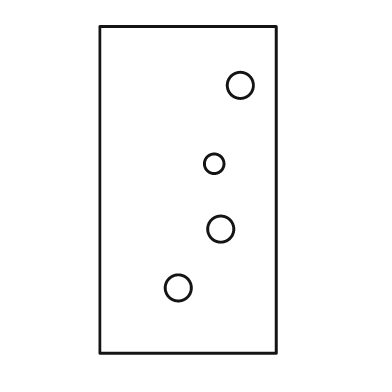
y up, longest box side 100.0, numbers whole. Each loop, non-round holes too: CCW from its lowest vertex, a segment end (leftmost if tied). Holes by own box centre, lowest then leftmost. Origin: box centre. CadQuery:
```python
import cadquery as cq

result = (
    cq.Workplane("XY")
    .moveTo(-27.0, -50.0)
    .lineTo(27.0, -50.0)
    .lineTo(27.0, 50.0)
    .lineTo(-27.0, 50.0)
    .close()
    .moveTo(-3.0, -30.0)
    .circle(4.0)
    .moveTo(10.0, -12.0)
    .circle(4.0)
    .moveTo(8.0, 8.0)
    .circle(3.0)
    .moveTo(16.0, 32.0)
    .circle(4.0)
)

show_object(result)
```